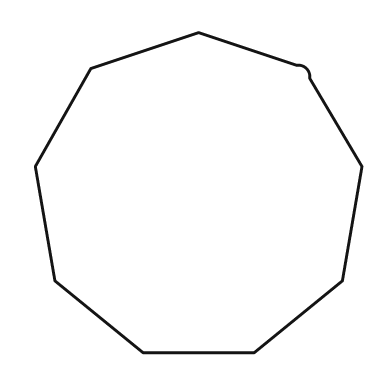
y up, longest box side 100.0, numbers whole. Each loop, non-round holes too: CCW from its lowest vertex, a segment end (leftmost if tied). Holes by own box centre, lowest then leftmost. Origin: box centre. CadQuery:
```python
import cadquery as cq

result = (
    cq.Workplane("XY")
    .moveTo(-17.0, -49.0)
    .lineTo(17.0, -49.0)
    .lineTo(44.0, -27.0)
    .lineTo(50.0, 8.0)
    .lineTo(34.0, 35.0)
    .threePointArc((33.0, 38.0), (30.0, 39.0))
    .lineTo(0.0, 49.0)
    .lineTo(-33.0, 38.0)
    .lineTo(-50.0, 8.0)
    .lineTo(-44.0, -27.0)
    .close()
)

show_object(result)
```